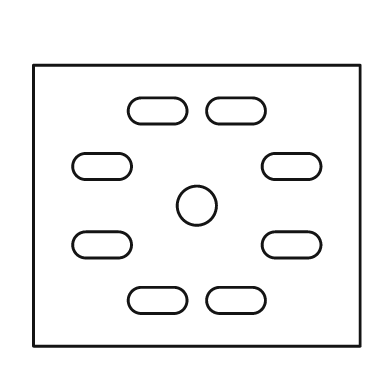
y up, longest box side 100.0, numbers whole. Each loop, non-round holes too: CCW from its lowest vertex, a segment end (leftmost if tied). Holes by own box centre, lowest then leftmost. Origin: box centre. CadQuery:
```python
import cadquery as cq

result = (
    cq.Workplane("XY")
    .moveTo(-50.0, -43.0)
    .lineTo(50.0, -43.0)
    .lineTo(50.0, 43.0)
    .lineTo(-50.0, 43.0)
    .close()
    .moveTo(-17.0, -33.0)
    .lineTo(-7.0, -33.0)
    .threePointArc((-3.0, -29.0), (-7.0, -25.0))
    .lineTo(-17.0, -25.0)
    .threePointArc((-21.0, -29.0), (-17.0, -33.0))
    .close()
    .moveTo(7.0, -33.0)
    .lineTo(17.0, -33.0)
    .threePointArc((21.0, -29.0), (17.0, -25.0))
    .lineTo(7.0, -25.0)
    .threePointArc((3.0, -29.0), (7.0, -33.0))
    .close()
    .moveTo(-34.0, -16.0)
    .lineTo(-24.0, -16.0)
    .threePointArc((-20.0, -12.0), (-24.0, -8.0))
    .lineTo(-34.0, -8.0)
    .threePointArc((-38.0, -12.0), (-34.0, -16.0))
    .close()
    .moveTo(24.0, -16.0)
    .lineTo(34.0, -16.0)
    .threePointArc((38.0, -12.0), (34.0, -8.0))
    .lineTo(24.0, -8.0)
    .threePointArc((20.0, -12.0), (24.0, -16.0))
    .close()
    .moveTo(0.0, 0.0)
    .circle(6.0)
    .moveTo(-34.0, 8.0)
    .lineTo(-24.0, 8.0)
    .threePointArc((-20.0, 12.0), (-24.0, 16.0))
    .lineTo(-34.0, 16.0)
    .threePointArc((-38.0, 12.0), (-34.0, 8.0))
    .close()
    .moveTo(24.0, 8.0)
    .lineTo(34.0, 8.0)
    .threePointArc((38.0, 12.0), (34.0, 16.0))
    .lineTo(24.0, 16.0)
    .threePointArc((20.0, 12.0), (24.0, 8.0))
    .close()
    .moveTo(-17.0, 25.0)
    .lineTo(-7.0, 25.0)
    .threePointArc((-3.0, 29.0), (-7.0, 33.0))
    .lineTo(-17.0, 33.0)
    .threePointArc((-21.0, 29.0), (-17.0, 25.0))
    .close()
    .moveTo(7.0, 25.0)
    .lineTo(17.0, 25.0)
    .threePointArc((21.0, 29.0), (17.0, 33.0))
    .lineTo(7.0, 33.0)
    .threePointArc((3.0, 29.0), (7.0, 25.0))
    .close()
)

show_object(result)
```